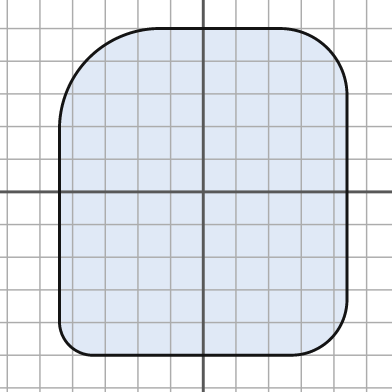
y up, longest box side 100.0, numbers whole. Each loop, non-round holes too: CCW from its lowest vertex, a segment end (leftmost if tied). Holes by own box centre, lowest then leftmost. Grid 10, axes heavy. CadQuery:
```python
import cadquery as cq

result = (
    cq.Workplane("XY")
    .moveTo(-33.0, -50.0)
    .lineTo(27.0, -50.0)
    .threePointArc((39.0, -45.0), (44.0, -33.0))
    .lineTo(44.0, 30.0)
    .threePointArc((38.0, 44.0), (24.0, 50.0))
    .lineTo(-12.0, 50.0)
    .threePointArc((-35.0, 41.0), (-44.0, 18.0))
    .lineTo(-44.0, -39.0)
    .threePointArc((-41.0, -47.0), (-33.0, -50.0))
    .close()
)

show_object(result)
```